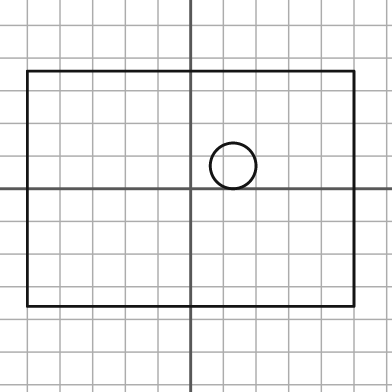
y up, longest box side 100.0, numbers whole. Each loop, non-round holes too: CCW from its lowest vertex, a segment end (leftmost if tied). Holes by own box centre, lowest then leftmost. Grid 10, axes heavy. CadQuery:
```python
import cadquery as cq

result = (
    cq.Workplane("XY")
    .moveTo(-50.0, -36.0)
    .lineTo(50.0, -36.0)
    .lineTo(50.0, 36.0)
    .lineTo(-50.0, 36.0)
    .close()
    .moveTo(13.0, 7.0)
    .circle(7.0)
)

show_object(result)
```